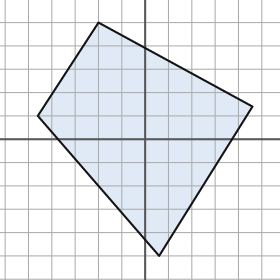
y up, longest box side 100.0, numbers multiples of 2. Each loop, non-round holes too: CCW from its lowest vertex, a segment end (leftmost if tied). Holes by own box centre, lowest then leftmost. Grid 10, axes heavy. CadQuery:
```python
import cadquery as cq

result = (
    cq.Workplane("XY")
    .moveTo(6.0, -50.0)
    .lineTo(46.0, 14.0)
    .lineTo(-20.0, 50.0)
    .lineTo(-46.0, 10.0)
    .close()
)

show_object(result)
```